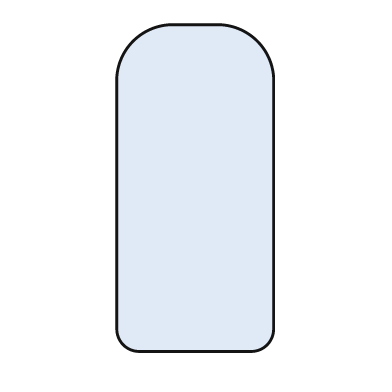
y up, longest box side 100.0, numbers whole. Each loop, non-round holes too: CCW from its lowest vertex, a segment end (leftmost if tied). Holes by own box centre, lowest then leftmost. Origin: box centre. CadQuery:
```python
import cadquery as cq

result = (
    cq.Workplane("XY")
    .moveTo(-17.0, -50.0)
    .lineTo(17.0, -50.0)
    .threePointArc((22.0, -48.0), (24.0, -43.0))
    .lineTo(24.0, 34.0)
    .threePointArc((19.0, 45.0), (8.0, 50.0))
    .lineTo(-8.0, 50.0)
    .threePointArc((-19.0, 45.0), (-24.0, 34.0))
    .lineTo(-24.0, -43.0)
    .threePointArc((-22.0, -48.0), (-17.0, -50.0))
    .close()
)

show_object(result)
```